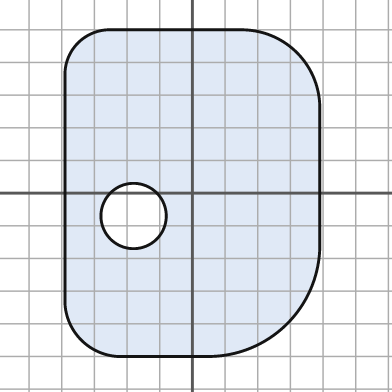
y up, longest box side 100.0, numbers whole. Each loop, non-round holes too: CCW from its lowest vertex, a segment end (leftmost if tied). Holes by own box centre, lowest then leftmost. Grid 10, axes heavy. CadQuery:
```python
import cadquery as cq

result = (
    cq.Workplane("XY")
    .moveTo(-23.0, -50.0)
    .lineTo(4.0, -50.0)
    .threePointArc((29.0, -40.0), (39.0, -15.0))
    .lineTo(39.0, 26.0)
    .threePointArc((32.0, 43.0), (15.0, 50.0))
    .lineTo(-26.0, 50.0)
    .threePointArc((-35.0, 46.0), (-39.0, 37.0))
    .lineTo(-39.0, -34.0)
    .threePointArc((-34.0, -45.0), (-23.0, -50.0))
    .close()
    .moveTo(-18.0, -7.0)
    .circle(10.0)
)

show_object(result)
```